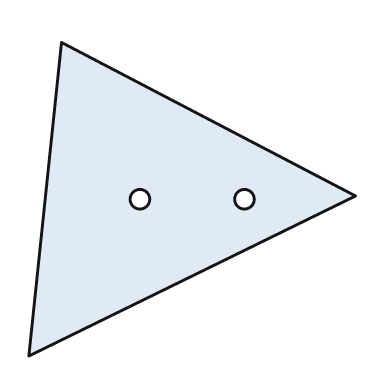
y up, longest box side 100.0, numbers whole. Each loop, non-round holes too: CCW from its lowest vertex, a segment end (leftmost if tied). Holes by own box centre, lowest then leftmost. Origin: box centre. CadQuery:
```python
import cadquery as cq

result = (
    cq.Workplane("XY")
    .moveTo(-50.0, -48.0)
    .lineTo(50.0, 1.0)
    .lineTo(-40.0, 48.0)
    .close()
    .moveTo(-16.0, 0.0)
    .circle(3.0)
    .moveTo(16.0, 0.0)
    .circle(3.0)
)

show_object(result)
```